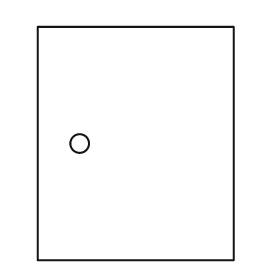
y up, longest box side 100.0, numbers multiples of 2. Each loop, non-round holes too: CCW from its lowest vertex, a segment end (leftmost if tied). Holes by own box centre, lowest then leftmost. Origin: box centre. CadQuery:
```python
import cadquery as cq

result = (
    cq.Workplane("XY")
    .moveTo(-42.0, -50.0)
    .lineTo(42.0, -50.0)
    .lineTo(42.0, 50.0)
    .lineTo(-42.0, 50.0)
    .close()
    .moveTo(-24.0, 0.0)
    .circle(4.0)
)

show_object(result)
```